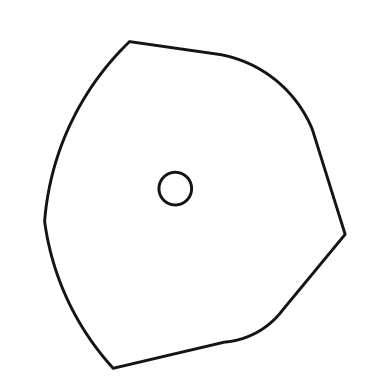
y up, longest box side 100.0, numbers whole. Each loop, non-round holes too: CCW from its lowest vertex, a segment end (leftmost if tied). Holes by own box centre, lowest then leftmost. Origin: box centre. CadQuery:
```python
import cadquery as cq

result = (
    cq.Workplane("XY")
    .moveTo(-25.0, -50.0)
    .lineTo(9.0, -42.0)
    .threePointArc((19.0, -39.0), (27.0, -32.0))
    .lineTo(46.0, -9.0)
    .lineTo(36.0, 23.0)
    .threePointArc((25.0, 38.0), (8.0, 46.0))
    .lineTo(-20.0, 50.0)
    .threePointArc((-38.0, 25.0), (-46.0, -5.0))
    .threePointArc((-39.0, -29.0), (-25.0, -50.0))
    .close()
    .moveTo(-6.0, 5.0)
    .circle(5.0)
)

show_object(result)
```